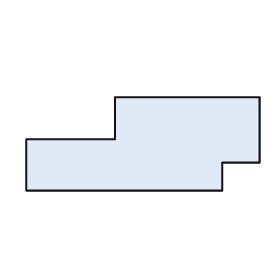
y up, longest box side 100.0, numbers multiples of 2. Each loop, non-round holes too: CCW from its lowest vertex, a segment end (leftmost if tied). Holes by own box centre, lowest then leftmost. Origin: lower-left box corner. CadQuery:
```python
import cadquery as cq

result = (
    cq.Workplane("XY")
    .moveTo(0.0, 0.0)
    .lineTo(84.0, 0.0)
    .lineTo(84.0, 12.0)
    .lineTo(100.0, 12.0)
    .lineTo(100.0, 40.0)
    .lineTo(38.0, 40.0)
    .lineTo(38.0, 22.0)
    .lineTo(0.0, 22.0)
    .close()
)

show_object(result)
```